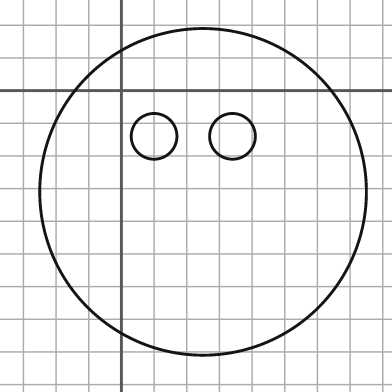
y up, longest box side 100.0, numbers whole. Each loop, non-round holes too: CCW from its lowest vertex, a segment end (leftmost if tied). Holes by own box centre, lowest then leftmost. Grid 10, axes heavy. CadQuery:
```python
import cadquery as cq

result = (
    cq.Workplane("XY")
    .moveTo(25.0, -31.0)
    .circle(50.0)
    .moveTo(10.0, -14.0)
    .circle(7.0)
    .moveTo(34.0, -14.0)
    .circle(7.0)
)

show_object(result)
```